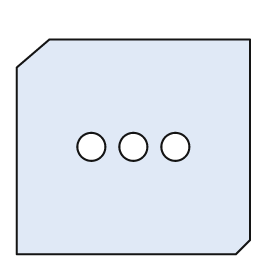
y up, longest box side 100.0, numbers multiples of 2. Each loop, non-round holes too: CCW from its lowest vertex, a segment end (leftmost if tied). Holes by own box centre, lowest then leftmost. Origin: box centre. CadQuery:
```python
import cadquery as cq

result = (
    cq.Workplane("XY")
    .moveTo(-50.0, -46.0)
    .lineTo(44.0, -46.0)
    .lineTo(50.0, -40.0)
    .lineTo(50.0, 46.0)
    .lineTo(-36.0, 46.0)
    .lineTo(-50.0, 34.0)
    .close()
    .moveTo(-18.0, 0.0)
    .circle(6.0)
    .moveTo(0.0, 0.0)
    .circle(6.0)
    .moveTo(18.0, 0.0)
    .circle(6.0)
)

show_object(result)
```